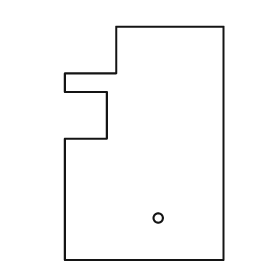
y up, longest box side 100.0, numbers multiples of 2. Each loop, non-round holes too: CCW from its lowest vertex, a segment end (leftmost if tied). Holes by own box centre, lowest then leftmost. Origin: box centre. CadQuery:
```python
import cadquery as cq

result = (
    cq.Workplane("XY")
    .moveTo(-34.0, -50.0)
    .lineTo(34.0, -50.0)
    .lineTo(34.0, 50.0)
    .lineTo(-12.0, 50.0)
    .lineTo(-12.0, 30.0)
    .lineTo(-34.0, 30.0)
    .lineTo(-34.0, 22.0)
    .lineTo(-16.0, 22.0)
    .lineTo(-16.0, 2.0)
    .lineTo(-34.0, 2.0)
    .close()
    .moveTo(6.0, -32.0)
    .circle(2.0)
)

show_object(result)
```